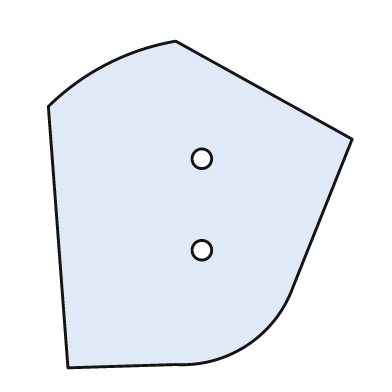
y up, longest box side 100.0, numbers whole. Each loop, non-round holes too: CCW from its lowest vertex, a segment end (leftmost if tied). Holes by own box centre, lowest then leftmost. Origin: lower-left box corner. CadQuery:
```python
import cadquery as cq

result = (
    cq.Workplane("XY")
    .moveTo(6.0, 0.0)
    .lineTo(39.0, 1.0)
    .threePointArc((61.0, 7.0), (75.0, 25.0))
    .lineTo(93.0, 70.0)
    .lineTo(39.0, 100.0)
    .threePointArc((18.0, 93.0), (0.0, 80.0))
    .close()
    .moveTo(47.0, 36.0)
    .circle(3.0)
    .moveTo(47.0, 64.0)
    .circle(3.0)
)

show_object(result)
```